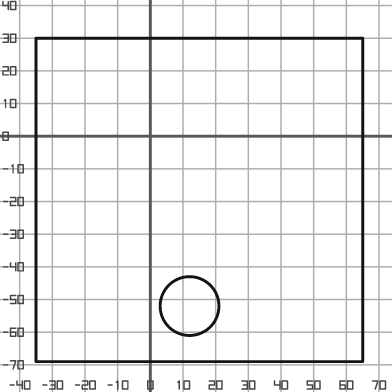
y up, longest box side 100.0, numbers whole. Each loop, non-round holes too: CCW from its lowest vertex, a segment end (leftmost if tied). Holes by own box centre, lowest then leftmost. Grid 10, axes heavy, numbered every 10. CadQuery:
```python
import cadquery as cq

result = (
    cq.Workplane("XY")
    .moveTo(-35.0, -69.0)
    .lineTo(65.0, -69.0)
    .lineTo(65.0, 30.0)
    .lineTo(-35.0, 30.0)
    .close()
    .moveTo(12.0, -52.0)
    .circle(9.0)
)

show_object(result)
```